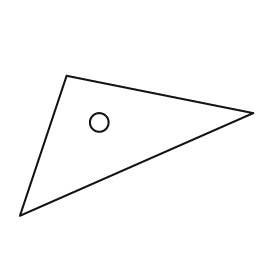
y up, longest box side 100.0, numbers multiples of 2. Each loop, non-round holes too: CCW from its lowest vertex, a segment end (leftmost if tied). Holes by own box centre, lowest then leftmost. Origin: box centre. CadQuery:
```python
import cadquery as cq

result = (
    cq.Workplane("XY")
    .moveTo(-50.0, -30.0)
    .lineTo(50.0, 14.0)
    .lineTo(-30.0, 30.0)
    .close()
    .moveTo(-16.0, 10.0)
    .circle(4.0)
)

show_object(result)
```